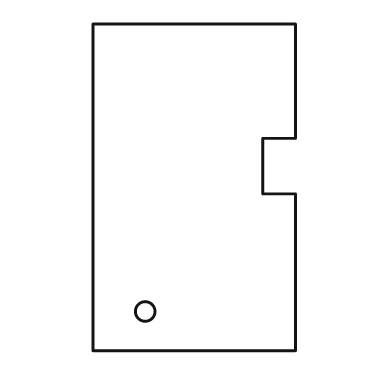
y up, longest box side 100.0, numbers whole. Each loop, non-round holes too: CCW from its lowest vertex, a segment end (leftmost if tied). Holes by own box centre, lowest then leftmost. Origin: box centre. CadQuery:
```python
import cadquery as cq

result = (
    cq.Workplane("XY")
    .moveTo(-31.0, -50.0)
    .lineTo(31.0, -50.0)
    .lineTo(31.0, -2.0)
    .lineTo(21.0, -2.0)
    .lineTo(21.0, 15.0)
    .lineTo(31.0, 15.0)
    .lineTo(31.0, 50.0)
    .lineTo(-31.0, 50.0)
    .close()
    .moveTo(-15.0, -38.0)
    .circle(3.0)
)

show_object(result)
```